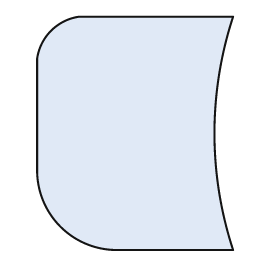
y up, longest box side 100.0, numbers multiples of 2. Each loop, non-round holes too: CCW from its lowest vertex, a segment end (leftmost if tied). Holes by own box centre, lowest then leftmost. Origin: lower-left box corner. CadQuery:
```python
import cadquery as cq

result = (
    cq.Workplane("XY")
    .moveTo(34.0, 0.0)
    .lineTo(84.0, 0.0)
    .threePointArc((76.0, 50.0), (84.0, 100.0))
    .lineTo(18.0, 100.0)
    .threePointArc((6.0, 94.0), (0.0, 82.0))
    .lineTo(0.0, 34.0)
    .threePointArc((10.0, 10.0), (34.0, 0.0))
    .close()
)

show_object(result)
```